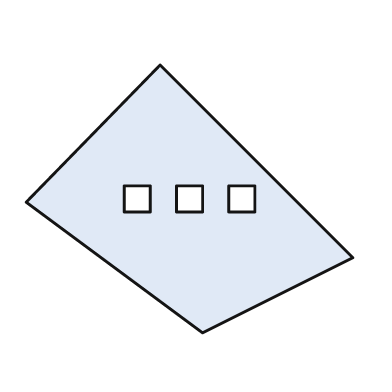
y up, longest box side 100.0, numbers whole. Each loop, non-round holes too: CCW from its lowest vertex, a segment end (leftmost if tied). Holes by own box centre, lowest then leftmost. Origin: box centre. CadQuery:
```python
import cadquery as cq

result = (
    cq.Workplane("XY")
    .moveTo(4.0, -41.0)
    .lineTo(50.0, -18.0)
    .lineTo(-9.0, 41.0)
    .lineTo(-50.0, -1.0)
    .close()
    .moveTo(-20.0, -4.0)
    .lineTo(-12.0, -4.0)
    .lineTo(-12.0, 4.0)
    .lineTo(-20.0, 4.0)
    .close()
    .moveTo(-4.0, -4.0)
    .lineTo(4.0, -4.0)
    .lineTo(4.0, 4.0)
    .lineTo(-4.0, 4.0)
    .close()
    .moveTo(12.0, -4.0)
    .lineTo(20.0, -4.0)
    .lineTo(20.0, 4.0)
    .lineTo(12.0, 4.0)
    .close()
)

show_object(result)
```